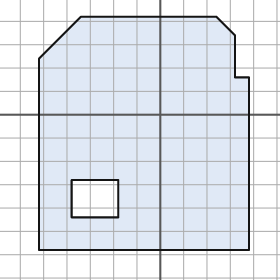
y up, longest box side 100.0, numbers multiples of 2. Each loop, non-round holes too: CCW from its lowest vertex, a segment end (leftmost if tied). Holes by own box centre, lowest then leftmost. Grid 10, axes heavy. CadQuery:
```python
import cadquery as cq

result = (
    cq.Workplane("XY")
    .moveTo(-52.0, -58.0)
    .lineTo(38.0, -58.0)
    .lineTo(38.0, 16.0)
    .lineTo(32.0, 16.0)
    .lineTo(32.0, 34.0)
    .lineTo(24.0, 42.0)
    .lineTo(-34.0, 42.0)
    .lineTo(-52.0, 24.0)
    .close()
    .moveTo(-38.0, -44.0)
    .lineTo(-18.0, -44.0)
    .lineTo(-18.0, -28.0)
    .lineTo(-38.0, -28.0)
    .close()
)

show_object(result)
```